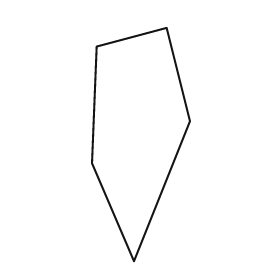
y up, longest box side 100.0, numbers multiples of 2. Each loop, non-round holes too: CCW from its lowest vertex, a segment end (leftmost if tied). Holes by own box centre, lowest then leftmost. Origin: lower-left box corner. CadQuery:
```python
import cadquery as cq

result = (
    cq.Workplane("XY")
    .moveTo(18.0, 0.0)
    .lineTo(42.0, 60.0)
    .lineTo(32.0, 100.0)
    .lineTo(2.0, 92.0)
    .lineTo(0.0, 42.0)
    .close()
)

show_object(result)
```